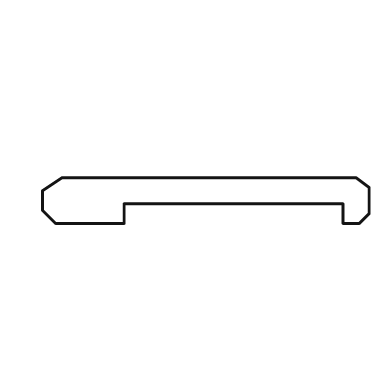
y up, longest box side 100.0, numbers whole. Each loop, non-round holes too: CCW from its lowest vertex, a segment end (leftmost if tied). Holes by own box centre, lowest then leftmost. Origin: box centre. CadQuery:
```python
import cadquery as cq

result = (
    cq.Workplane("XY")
    .moveTo(-46.0, -7.0)
    .lineTo(-25.0, -7.0)
    .lineTo(-25.0, -1.0)
    .lineTo(42.0, -1.0)
    .lineTo(42.0, -7.0)
    .lineTo(47.0, -7.0)
    .lineTo(50.0, -4.0)
    .lineTo(50.0, 4.0)
    .lineTo(46.0, 7.0)
    .lineTo(-44.0, 7.0)
    .lineTo(-50.0, 3.0)
    .lineTo(-50.0, -3.0)
    .close()
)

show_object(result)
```